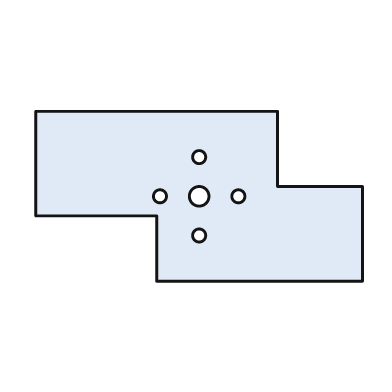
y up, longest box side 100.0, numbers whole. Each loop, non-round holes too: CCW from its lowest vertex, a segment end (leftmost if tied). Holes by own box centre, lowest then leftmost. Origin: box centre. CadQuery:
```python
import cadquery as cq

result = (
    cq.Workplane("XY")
    .moveTo(-13.0, -26.0)
    .lineTo(50.0, -26.0)
    .lineTo(50.0, 3.0)
    .lineTo(24.0, 3.0)
    .lineTo(24.0, 26.0)
    .lineTo(-50.0, 26.0)
    .lineTo(-50.0, -6.0)
    .lineTo(-13.0, -6.0)
    .close()
    .moveTo(0.0, -12.0)
    .circle(2.0)
    .moveTo(-12.0, 0.0)
    .circle(2.0)
    .moveTo(0.0, 0.0)
    .circle(3.0)
    .moveTo(12.0, 0.0)
    .circle(2.0)
    .moveTo(0.0, 12.0)
    .circle(2.0)
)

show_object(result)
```